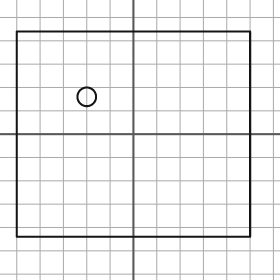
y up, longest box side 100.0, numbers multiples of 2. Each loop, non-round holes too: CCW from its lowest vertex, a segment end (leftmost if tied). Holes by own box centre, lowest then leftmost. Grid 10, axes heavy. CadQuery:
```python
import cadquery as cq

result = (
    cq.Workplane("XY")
    .moveTo(-50.0, -44.0)
    .lineTo(50.0, -44.0)
    .lineTo(50.0, 44.0)
    .lineTo(-50.0, 44.0)
    .close()
    .moveTo(-20.0, 16.0)
    .circle(4.0)
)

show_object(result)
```